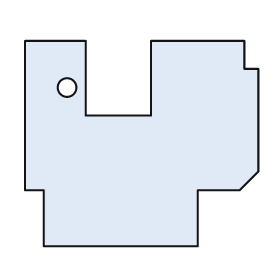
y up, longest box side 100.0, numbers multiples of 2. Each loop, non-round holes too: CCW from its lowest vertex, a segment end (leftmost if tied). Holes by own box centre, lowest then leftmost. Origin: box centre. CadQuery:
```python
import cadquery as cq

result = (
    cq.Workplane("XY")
    .moveTo(-42.0, -44.0)
    .lineTo(24.0, -44.0)
    .lineTo(24.0, -20.0)
    .lineTo(42.0, -20.0)
    .lineTo(50.0, -12.0)
    .lineTo(50.0, 32.0)
    .lineTo(44.0, 32.0)
    .lineTo(44.0, 44.0)
    .lineTo(4.0, 44.0)
    .lineTo(4.0, 12.0)
    .lineTo(-24.0, 12.0)
    .lineTo(-24.0, 44.0)
    .lineTo(-50.0, 44.0)
    .lineTo(-50.0, -20.0)
    .lineTo(-42.0, -20.0)
    .close()
    .moveTo(-32.0, 24.0)
    .circle(4.0)
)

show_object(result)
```